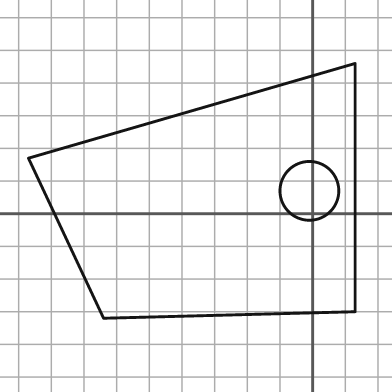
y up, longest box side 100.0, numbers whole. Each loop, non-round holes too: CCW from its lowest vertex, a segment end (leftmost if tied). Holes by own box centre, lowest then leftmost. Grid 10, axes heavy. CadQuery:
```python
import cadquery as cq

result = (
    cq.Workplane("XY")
    .moveTo(-64.0, -32.0)
    .lineTo(13.0, -30.0)
    .lineTo(13.0, 46.0)
    .lineTo(-87.0, 17.0)
    .close()
    .moveTo(-1.0, 7.0)
    .circle(9.0)
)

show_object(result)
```